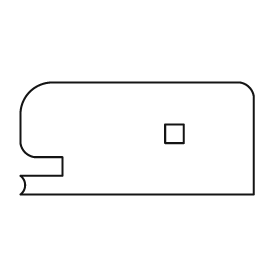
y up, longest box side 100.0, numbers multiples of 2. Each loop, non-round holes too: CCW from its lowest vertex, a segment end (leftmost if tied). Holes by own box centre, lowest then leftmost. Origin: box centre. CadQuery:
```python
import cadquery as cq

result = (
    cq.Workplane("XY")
    .moveTo(-50.0, -24.0)
    .lineTo(50.0, -24.0)
    .lineTo(50.0, 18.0)
    .threePointArc((48.0, 22.0), (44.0, 24.0))
    .lineTo(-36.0, 24.0)
    .threePointArc((-46.0, 20.0), (-50.0, 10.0))
    .lineTo(-50.0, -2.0)
    .threePointArc((-48.0, -6.0), (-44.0, -8.0))
    .lineTo(-32.0, -8.0)
    .lineTo(-32.0, -16.0)
    .lineTo(-50.0, -16.0)
    .threePointArc((-48.0, -20.0), (-50.0, -24.0))
    .close()
    .moveTo(12.0, -2.0)
    .lineTo(20.0, -2.0)
    .lineTo(20.0, 6.0)
    .lineTo(12.0, 6.0)
    .close()
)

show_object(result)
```